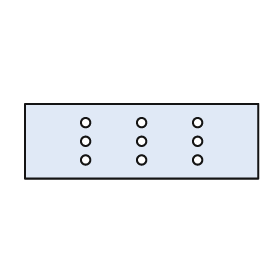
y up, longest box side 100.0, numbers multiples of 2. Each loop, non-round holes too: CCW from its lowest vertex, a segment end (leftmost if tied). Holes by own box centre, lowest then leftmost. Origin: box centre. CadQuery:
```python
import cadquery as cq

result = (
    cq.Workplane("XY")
    .moveTo(-50.0, -16.0)
    .lineTo(50.0, -16.0)
    .lineTo(50.0, 16.0)
    .lineTo(-50.0, 16.0)
    .close()
    .moveTo(-24.0, -8.0)
    .circle(2.0)
    .moveTo(0.0, -8.0)
    .circle(2.0)
    .moveTo(24.0, -8.0)
    .circle(2.0)
    .moveTo(-24.0, 0.0)
    .circle(2.0)
    .moveTo(0.0, 0.0)
    .circle(2.0)
    .moveTo(24.0, 0.0)
    .circle(2.0)
    .moveTo(-24.0, 8.0)
    .circle(2.0)
    .moveTo(0.0, 8.0)
    .circle(2.0)
    .moveTo(24.0, 8.0)
    .circle(2.0)
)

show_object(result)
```